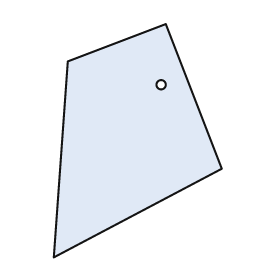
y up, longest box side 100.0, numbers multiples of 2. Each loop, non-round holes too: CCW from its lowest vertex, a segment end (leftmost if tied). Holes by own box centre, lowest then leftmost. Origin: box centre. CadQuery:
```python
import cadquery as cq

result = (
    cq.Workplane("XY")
    .moveTo(-36.0, -50.0)
    .lineTo(36.0, -12.0)
    .lineTo(12.0, 50.0)
    .lineTo(-30.0, 34.0)
    .close()
    .moveTo(10.0, 24.0)
    .circle(2.0)
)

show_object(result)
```